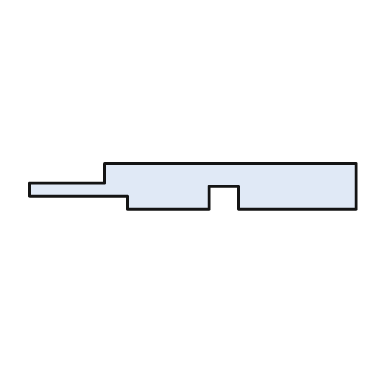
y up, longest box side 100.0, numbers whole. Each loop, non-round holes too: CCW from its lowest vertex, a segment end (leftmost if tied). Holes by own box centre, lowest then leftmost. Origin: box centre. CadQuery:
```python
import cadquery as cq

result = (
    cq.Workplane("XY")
    .moveTo(-20.0, -7.0)
    .lineTo(5.0, -7.0)
    .lineTo(5.0, 0.0)
    .lineTo(14.0, 0.0)
    .lineTo(14.0, -7.0)
    .lineTo(50.0, -7.0)
    .lineTo(50.0, 7.0)
    .lineTo(-27.0, 7.0)
    .lineTo(-27.0, 1.0)
    .lineTo(-50.0, 1.0)
    .lineTo(-50.0, -3.0)
    .lineTo(-20.0, -3.0)
    .close()
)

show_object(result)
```